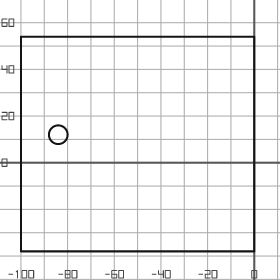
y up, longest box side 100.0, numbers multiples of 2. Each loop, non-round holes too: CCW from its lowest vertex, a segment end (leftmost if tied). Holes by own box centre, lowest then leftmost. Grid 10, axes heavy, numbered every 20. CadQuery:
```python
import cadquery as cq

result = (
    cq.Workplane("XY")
    .moveTo(-100.0, -38.0)
    .lineTo(0.0, -38.0)
    .lineTo(0.0, 54.0)
    .lineTo(-100.0, 54.0)
    .close()
    .moveTo(-84.0, 12.0)
    .circle(4.0)
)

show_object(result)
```